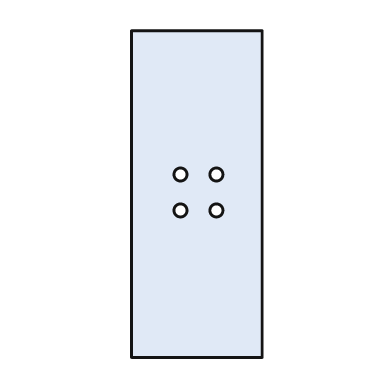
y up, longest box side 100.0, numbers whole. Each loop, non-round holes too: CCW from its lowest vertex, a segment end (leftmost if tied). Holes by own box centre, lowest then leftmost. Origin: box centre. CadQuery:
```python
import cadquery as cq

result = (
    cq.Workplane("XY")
    .moveTo(-20.0, -50.0)
    .lineTo(20.0, -50.0)
    .lineTo(20.0, 50.0)
    .lineTo(-20.0, 50.0)
    .close()
    .moveTo(-5.0, -5.0)
    .circle(2.0)
    .moveTo(6.0, -5.0)
    .circle(2.0)
    .moveTo(-5.0, 6.0)
    .circle(2.0)
    .moveTo(6.0, 6.0)
    .circle(2.0)
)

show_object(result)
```